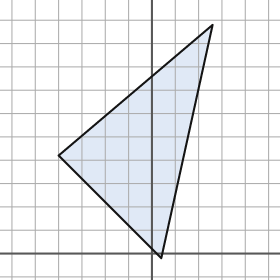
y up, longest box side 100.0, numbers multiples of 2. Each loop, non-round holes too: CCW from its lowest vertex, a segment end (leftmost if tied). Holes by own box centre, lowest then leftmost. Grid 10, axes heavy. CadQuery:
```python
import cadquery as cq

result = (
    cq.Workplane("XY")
    .moveTo(4.0, -2.0)
    .lineTo(26.0, 98.0)
    .lineTo(-40.0, 42.0)
    .close()
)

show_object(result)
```